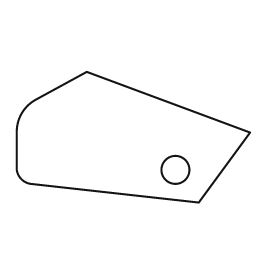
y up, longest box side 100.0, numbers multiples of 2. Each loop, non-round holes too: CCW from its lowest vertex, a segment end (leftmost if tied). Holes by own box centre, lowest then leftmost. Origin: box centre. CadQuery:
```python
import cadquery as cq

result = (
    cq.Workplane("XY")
    .moveTo(28.0, -28.0)
    .lineTo(50.0, 2.0)
    .lineTo(-20.0, 28.0)
    .lineTo(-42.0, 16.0)
    .threePointArc((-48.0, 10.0), (-50.0, 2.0))
    .lineTo(-50.0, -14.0)
    .threePointArc((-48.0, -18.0), (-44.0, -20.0))
    .close()
    .moveTo(18.0, -14.0)
    .circle(6.0)
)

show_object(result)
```